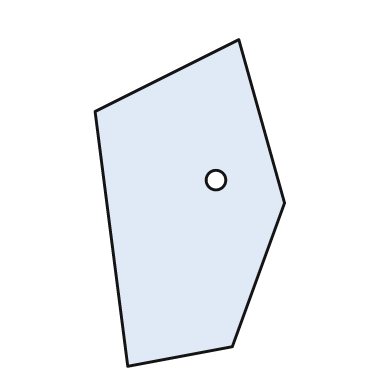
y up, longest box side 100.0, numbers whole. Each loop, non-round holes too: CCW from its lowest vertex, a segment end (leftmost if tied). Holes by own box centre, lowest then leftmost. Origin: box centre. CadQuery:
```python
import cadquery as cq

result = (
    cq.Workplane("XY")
    .moveTo(-19.0, -50.0)
    .lineTo(13.0, -44.0)
    .lineTo(29.0, 0.0)
    .lineTo(15.0, 50.0)
    .lineTo(-29.0, 28.0)
    .close()
    .moveTo(8.0, 7.0)
    .circle(3.0)
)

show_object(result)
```